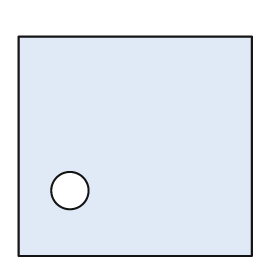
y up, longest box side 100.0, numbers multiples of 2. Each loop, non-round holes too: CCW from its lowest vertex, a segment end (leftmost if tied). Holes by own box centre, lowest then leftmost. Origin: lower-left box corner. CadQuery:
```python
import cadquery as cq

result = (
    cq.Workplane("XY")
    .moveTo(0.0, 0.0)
    .lineTo(100.0, 0.0)
    .lineTo(100.0, 94.0)
    .lineTo(0.0, 94.0)
    .close()
    .moveTo(22.0, 28.0)
    .circle(8.0)
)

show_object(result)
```